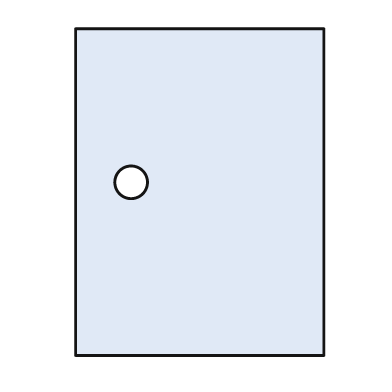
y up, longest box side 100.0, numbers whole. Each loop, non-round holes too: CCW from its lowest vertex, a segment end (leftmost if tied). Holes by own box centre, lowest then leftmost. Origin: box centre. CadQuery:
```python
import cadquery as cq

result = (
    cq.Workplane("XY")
    .moveTo(-38.0, -50.0)
    .lineTo(38.0, -50.0)
    .lineTo(38.0, 50.0)
    .lineTo(-38.0, 50.0)
    .close()
    .moveTo(-21.0, 3.0)
    .circle(5.0)
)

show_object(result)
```